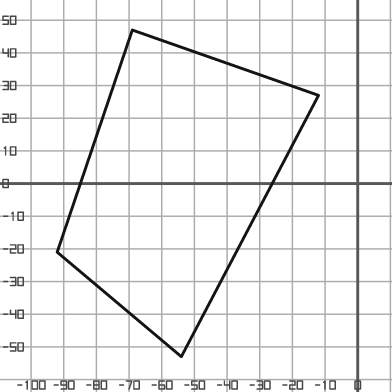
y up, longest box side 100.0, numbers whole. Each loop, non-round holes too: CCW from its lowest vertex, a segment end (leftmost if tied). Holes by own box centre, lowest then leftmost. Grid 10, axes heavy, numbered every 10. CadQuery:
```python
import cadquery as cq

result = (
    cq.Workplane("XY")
    .moveTo(-54.0, -53.0)
    .lineTo(-12.0, 27.0)
    .lineTo(-69.0, 47.0)
    .lineTo(-92.0, -21.0)
    .close()
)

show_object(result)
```